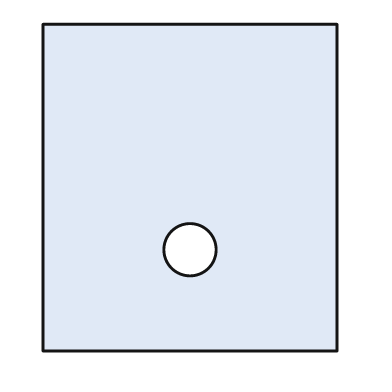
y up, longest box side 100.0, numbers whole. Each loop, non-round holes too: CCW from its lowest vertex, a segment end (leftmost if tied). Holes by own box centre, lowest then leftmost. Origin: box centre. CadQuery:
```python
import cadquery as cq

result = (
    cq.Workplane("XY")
    .moveTo(-45.0, -50.0)
    .lineTo(45.0, -50.0)
    .lineTo(45.0, 50.0)
    .lineTo(-45.0, 50.0)
    .close()
    .moveTo(0.0, -19.0)
    .circle(8.0)
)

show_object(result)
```